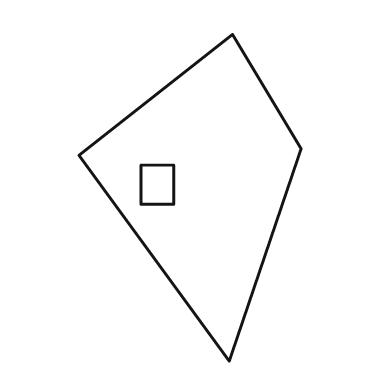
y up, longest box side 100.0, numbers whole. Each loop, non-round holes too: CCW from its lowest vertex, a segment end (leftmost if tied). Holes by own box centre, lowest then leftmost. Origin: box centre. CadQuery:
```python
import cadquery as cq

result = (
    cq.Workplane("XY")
    .moveTo(12.0, -50.0)
    .lineTo(34.0, 15.0)
    .lineTo(13.0, 50.0)
    .lineTo(-34.0, 13.0)
    .close()
    .moveTo(-15.0, -2.0)
    .lineTo(-5.0, -2.0)
    .lineTo(-5.0, 10.0)
    .lineTo(-15.0, 10.0)
    .close()
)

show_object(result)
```